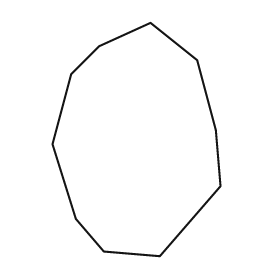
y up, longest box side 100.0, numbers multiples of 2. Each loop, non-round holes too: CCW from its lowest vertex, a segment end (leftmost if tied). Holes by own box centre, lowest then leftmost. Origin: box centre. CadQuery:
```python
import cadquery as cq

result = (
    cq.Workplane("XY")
    .moveTo(10.0, -50.0)
    .lineTo(36.0, -20.0)
    .lineTo(34.0, 4.0)
    .lineTo(26.0, 34.0)
    .lineTo(6.0, 50.0)
    .lineTo(-16.0, 40.0)
    .lineTo(-28.0, 28.0)
    .lineTo(-36.0, -2.0)
    .lineTo(-26.0, -34.0)
    .lineTo(-14.0, -48.0)
    .close()
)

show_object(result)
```